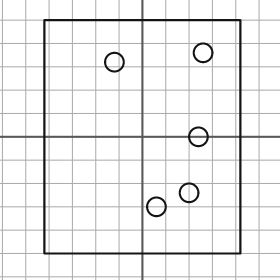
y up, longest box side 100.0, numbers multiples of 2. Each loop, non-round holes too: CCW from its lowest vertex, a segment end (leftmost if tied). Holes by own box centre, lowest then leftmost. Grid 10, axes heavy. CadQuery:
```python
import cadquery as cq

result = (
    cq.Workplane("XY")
    .moveTo(-42.0, -50.0)
    .lineTo(42.0, -50.0)
    .lineTo(42.0, 50.0)
    .lineTo(-42.0, 50.0)
    .close()
    .moveTo(6.0, -30.0)
    .circle(4.0)
    .moveTo(20.0, -24.0)
    .circle(4.0)
    .moveTo(24.0, 0.0)
    .circle(4.0)
    .moveTo(-12.0, 32.0)
    .circle(4.0)
    .moveTo(26.0, 36.0)
    .circle(4.0)
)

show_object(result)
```